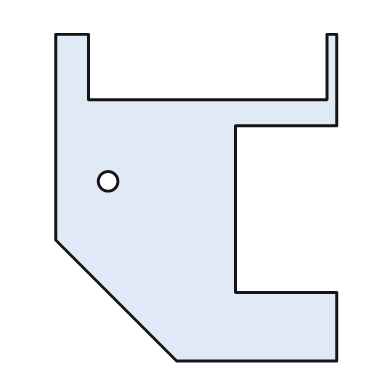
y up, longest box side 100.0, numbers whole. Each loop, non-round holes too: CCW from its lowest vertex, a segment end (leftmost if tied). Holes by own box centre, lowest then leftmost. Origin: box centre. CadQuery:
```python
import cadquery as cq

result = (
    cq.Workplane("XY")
    .moveTo(-6.0, -50.0)
    .lineTo(43.0, -50.0)
    .lineTo(43.0, -29.0)
    .lineTo(12.0, -29.0)
    .lineTo(12.0, 22.0)
    .lineTo(43.0, 22.0)
    .lineTo(43.0, 50.0)
    .lineTo(40.0, 50.0)
    .lineTo(40.0, 30.0)
    .lineTo(-33.0, 30.0)
    .lineTo(-33.0, 50.0)
    .lineTo(-43.0, 50.0)
    .lineTo(-43.0, -13.0)
    .close()
    .moveTo(-27.0, 5.0)
    .circle(3.0)
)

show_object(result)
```